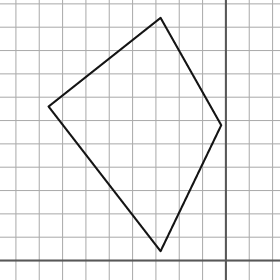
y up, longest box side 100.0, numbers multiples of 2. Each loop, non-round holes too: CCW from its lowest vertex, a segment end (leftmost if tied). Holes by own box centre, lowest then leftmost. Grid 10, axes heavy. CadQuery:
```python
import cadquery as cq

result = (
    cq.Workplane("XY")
    .moveTo(-28.0, 4.0)
    .lineTo(-2.0, 58.0)
    .lineTo(-28.0, 104.0)
    .lineTo(-76.0, 66.0)
    .close()
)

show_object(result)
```